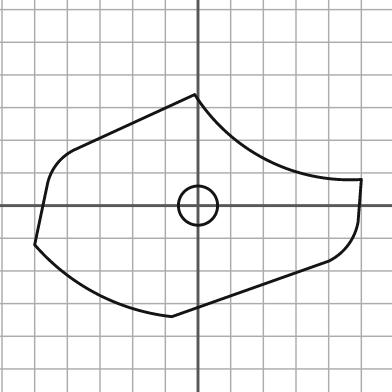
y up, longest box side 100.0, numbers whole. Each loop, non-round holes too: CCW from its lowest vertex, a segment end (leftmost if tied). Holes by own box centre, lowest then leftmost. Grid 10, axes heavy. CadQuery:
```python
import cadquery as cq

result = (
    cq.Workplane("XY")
    .moveTo(-8.0, -34.0)
    .lineTo(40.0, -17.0)
    .threePointArc((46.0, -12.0), (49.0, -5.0))
    .lineTo(50.0, 8.0)
    .threePointArc((21.0, 14.0), (-1.0, 34.0))
    .lineTo(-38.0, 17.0)
    .threePointArc((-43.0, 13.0), (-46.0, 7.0))
    .lineTo(-50.0, -12.0)
    .threePointArc((-31.0, -27.0), (-8.0, -34.0))
    .close()
    .moveTo(0.0, 0.0)
    .circle(6.0)
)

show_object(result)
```